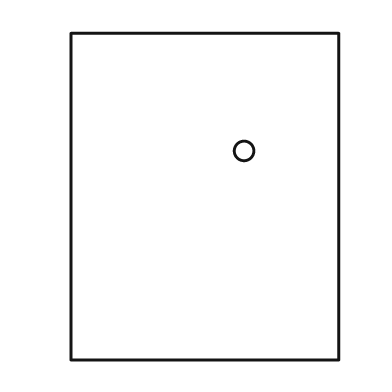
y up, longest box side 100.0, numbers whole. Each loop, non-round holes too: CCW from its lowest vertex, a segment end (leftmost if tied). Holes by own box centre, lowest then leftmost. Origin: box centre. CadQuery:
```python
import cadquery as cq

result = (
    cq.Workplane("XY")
    .moveTo(-41.0, -50.0)
    .lineTo(41.0, -50.0)
    .lineTo(41.0, 50.0)
    .lineTo(-41.0, 50.0)
    .close()
    .moveTo(12.0, 14.0)
    .circle(3.0)
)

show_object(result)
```